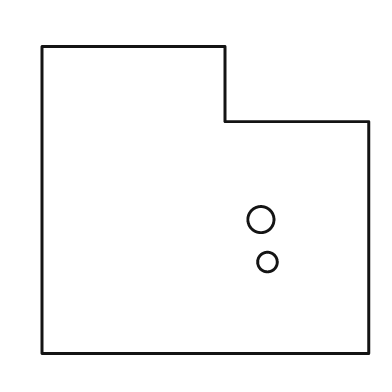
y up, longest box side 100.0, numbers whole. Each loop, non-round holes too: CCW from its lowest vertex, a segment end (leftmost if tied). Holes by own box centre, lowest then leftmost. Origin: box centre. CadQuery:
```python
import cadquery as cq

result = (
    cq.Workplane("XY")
    .moveTo(-50.0, -47.0)
    .lineTo(50.0, -47.0)
    .lineTo(50.0, 24.0)
    .lineTo(6.0, 24.0)
    .lineTo(6.0, 47.0)
    .lineTo(-50.0, 47.0)
    .close()
    .moveTo(19.0, -19.0)
    .circle(3.0)
    .moveTo(17.0, -6.0)
    .circle(4.0)
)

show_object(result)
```